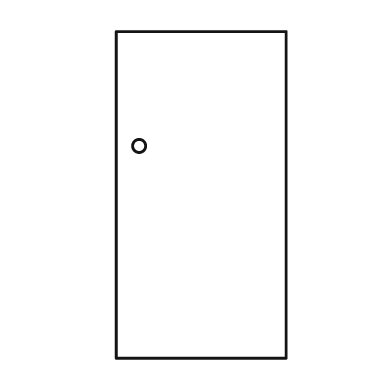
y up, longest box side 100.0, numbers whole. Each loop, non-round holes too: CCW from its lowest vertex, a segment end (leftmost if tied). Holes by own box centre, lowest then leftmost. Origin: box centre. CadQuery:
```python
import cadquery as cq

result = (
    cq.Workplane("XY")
    .moveTo(-26.0, -50.0)
    .lineTo(26.0, -50.0)
    .lineTo(26.0, 50.0)
    .lineTo(-26.0, 50.0)
    .close()
    .moveTo(-19.0, 15.0)
    .circle(2.0)
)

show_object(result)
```